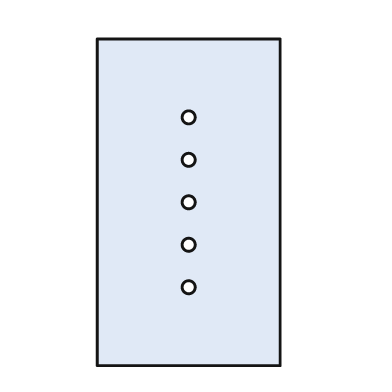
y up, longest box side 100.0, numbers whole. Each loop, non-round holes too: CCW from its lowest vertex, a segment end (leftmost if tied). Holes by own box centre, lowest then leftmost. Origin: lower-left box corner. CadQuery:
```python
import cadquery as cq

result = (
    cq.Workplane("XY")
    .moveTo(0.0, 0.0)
    .lineTo(56.0, 0.0)
    .lineTo(56.0, 100.0)
    .lineTo(0.0, 100.0)
    .close()
    .moveTo(28.0, 24.0)
    .circle(2.0)
    .moveTo(28.0, 37.0)
    .circle(2.0)
    .moveTo(28.0, 50.0)
    .circle(2.0)
    .moveTo(28.0, 63.0)
    .circle(2.0)
    .moveTo(28.0, 76.0)
    .circle(2.0)
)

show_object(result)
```